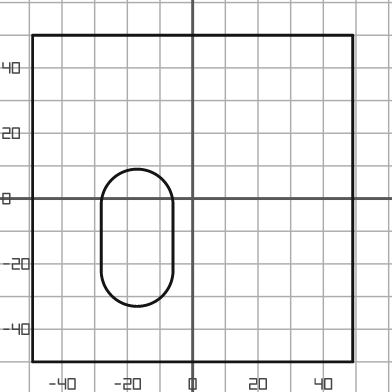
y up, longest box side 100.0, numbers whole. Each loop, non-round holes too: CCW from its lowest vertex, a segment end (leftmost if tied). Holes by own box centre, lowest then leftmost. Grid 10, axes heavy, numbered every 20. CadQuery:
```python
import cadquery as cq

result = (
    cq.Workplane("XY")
    .moveTo(-49.0, -50.0)
    .lineTo(49.0, -50.0)
    .lineTo(49.0, 50.0)
    .lineTo(-49.0, 50.0)
    .close()
    .moveTo(-28.0, -22.0)
    .threePointArc((-17.0, -33.0), (-6.0, -22.0))
    .lineTo(-6.0, -2.0)
    .threePointArc((-17.0, 9.0), (-28.0, -2.0))
    .close()
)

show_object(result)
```